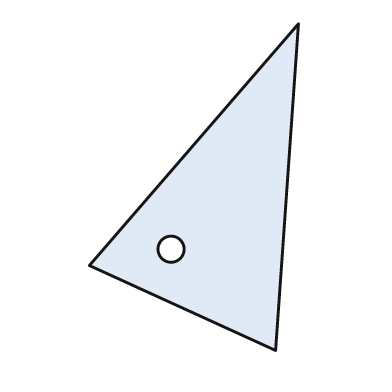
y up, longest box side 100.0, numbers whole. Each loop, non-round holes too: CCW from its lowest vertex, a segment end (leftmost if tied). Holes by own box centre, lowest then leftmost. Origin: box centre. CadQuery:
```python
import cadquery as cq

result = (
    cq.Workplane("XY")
    .moveTo(25.0, -50.0)
    .lineTo(32.0, 50.0)
    .lineTo(-32.0, -24.0)
    .close()
    .moveTo(-7.0, -19.0)
    .circle(4.0)
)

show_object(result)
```